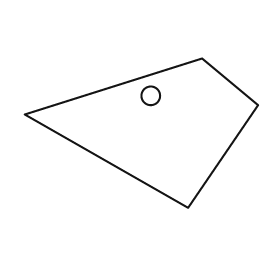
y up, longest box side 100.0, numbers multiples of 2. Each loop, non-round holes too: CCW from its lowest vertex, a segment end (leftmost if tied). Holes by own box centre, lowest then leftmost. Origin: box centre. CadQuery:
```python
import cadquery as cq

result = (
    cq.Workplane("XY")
    .moveTo(20.0, -32.0)
    .lineTo(50.0, 12.0)
    .lineTo(26.0, 32.0)
    .lineTo(-50.0, 8.0)
    .close()
    .moveTo(4.0, 16.0)
    .circle(4.0)
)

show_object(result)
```